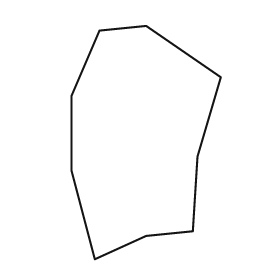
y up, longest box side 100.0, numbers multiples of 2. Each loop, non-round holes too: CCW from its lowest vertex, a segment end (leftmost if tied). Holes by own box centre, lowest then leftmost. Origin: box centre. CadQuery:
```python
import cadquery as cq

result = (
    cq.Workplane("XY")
    .moveTo(-22.0, -50.0)
    .lineTo(0.0, -40.0)
    .lineTo(20.0, -38.0)
    .lineTo(22.0, -6.0)
    .lineTo(32.0, 28.0)
    .lineTo(0.0, 50.0)
    .lineTo(-20.0, 48.0)
    .lineTo(-32.0, 20.0)
    .lineTo(-32.0, -12.0)
    .close()
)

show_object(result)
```